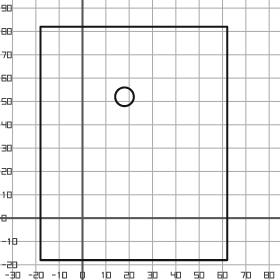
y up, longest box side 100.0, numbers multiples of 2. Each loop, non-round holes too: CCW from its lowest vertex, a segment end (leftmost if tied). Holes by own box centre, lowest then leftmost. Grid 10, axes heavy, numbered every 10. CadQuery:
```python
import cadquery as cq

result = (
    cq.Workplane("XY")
    .moveTo(-18.0, -18.0)
    .lineTo(62.0, -18.0)
    .lineTo(62.0, 82.0)
    .lineTo(-18.0, 82.0)
    .close()
    .moveTo(18.0, 52.0)
    .circle(4.0)
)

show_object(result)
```